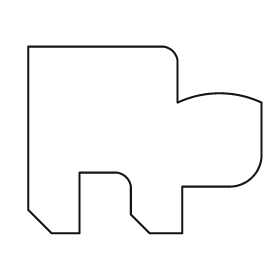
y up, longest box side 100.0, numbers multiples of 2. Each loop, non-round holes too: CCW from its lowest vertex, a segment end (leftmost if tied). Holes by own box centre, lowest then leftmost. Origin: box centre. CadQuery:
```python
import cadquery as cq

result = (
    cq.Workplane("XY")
    .moveTo(-40.0, -40.0)
    .lineTo(-28.0, -40.0)
    .lineTo(-28.0, -14.0)
    .lineTo(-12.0, -14.0)
    .threePointArc((-8.0, -16.0), (-6.0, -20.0))
    .lineTo(-6.0, -32.0)
    .lineTo(2.0, -40.0)
    .lineTo(16.0, -40.0)
    .lineTo(16.0, -20.0)
    .lineTo(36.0, -20.0)
    .threePointArc((46.0, -16.0), (50.0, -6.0))
    .lineTo(50.0, 16.0)
    .threePointArc((32.0, 20.0), (14.0, 16.0))
    .lineTo(14.0, 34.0)
    .threePointArc((12.0, 38.0), (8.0, 40.0))
    .lineTo(-50.0, 40.0)
    .lineTo(-50.0, -30.0)
    .close()
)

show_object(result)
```